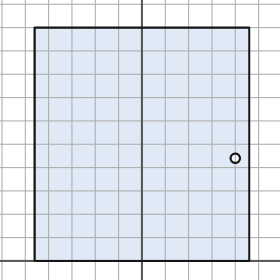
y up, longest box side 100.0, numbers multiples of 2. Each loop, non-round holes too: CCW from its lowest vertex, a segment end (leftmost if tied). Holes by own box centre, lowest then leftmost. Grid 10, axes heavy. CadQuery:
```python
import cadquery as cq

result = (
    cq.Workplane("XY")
    .moveTo(-46.0, 0.0)
    .lineTo(46.0, 0.0)
    .lineTo(46.0, 100.0)
    .lineTo(-46.0, 100.0)
    .close()
    .moveTo(40.0, 44.0)
    .circle(2.0)
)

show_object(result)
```